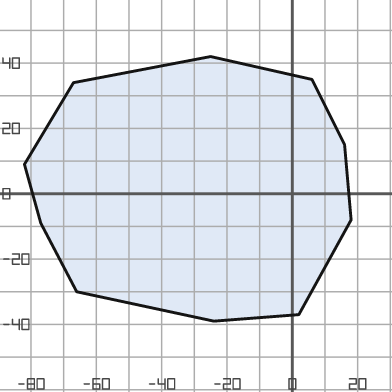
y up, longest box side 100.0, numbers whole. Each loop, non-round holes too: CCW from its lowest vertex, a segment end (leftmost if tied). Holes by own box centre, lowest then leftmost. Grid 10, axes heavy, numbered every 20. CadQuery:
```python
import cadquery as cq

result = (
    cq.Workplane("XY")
    .moveTo(-24.0, -39.0)
    .lineTo(2.0, -37.0)
    .lineTo(18.0, -8.0)
    .lineTo(16.0, 15.0)
    .lineTo(6.0, 35.0)
    .lineTo(-25.0, 42.0)
    .lineTo(-67.0, 34.0)
    .lineTo(-82.0, 9.0)
    .lineTo(-77.0, -9.0)
    .lineTo(-66.0, -30.0)
    .close()
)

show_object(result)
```